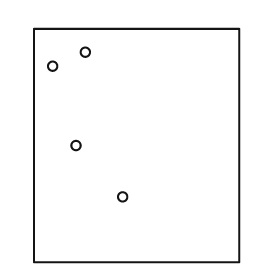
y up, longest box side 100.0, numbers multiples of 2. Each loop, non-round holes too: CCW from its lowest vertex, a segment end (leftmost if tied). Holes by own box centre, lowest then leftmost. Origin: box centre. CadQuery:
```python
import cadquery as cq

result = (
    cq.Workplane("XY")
    .moveTo(-44.0, -50.0)
    .lineTo(44.0, -50.0)
    .lineTo(44.0, 50.0)
    .lineTo(-44.0, 50.0)
    .close()
    .moveTo(-6.0, -22.0)
    .circle(2.0)
    .moveTo(-26.0, 0.0)
    .circle(2.0)
    .moveTo(-36.0, 34.0)
    .circle(2.0)
    .moveTo(-22.0, 40.0)
    .circle(2.0)
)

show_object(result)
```